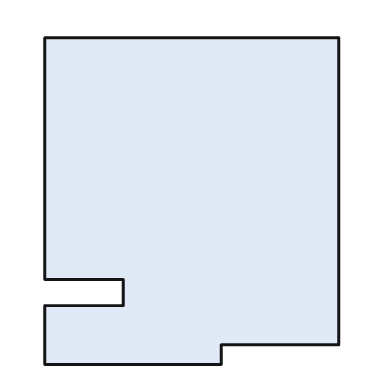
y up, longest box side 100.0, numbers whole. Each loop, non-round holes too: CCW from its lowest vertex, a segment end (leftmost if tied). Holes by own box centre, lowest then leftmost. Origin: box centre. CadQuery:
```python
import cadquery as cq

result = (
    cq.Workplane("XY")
    .moveTo(-45.0, -50.0)
    .lineTo(9.0, -50.0)
    .lineTo(9.0, -44.0)
    .lineTo(45.0, -44.0)
    .lineTo(45.0, 50.0)
    .lineTo(-45.0, 50.0)
    .lineTo(-45.0, -24.0)
    .lineTo(-21.0, -24.0)
    .lineTo(-21.0, -32.0)
    .lineTo(-45.0, -32.0)
    .close()
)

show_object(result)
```